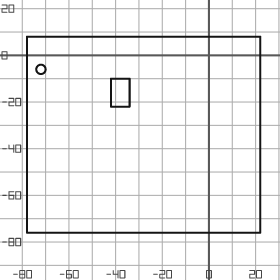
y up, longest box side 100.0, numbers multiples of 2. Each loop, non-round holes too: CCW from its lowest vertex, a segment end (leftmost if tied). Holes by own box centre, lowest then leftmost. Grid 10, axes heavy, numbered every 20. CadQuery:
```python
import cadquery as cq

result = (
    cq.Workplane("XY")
    .moveTo(-78.0, -76.0)
    .lineTo(22.0, -76.0)
    .lineTo(22.0, 8.0)
    .lineTo(-78.0, 8.0)
    .close()
    .moveTo(-42.0, -22.0)
    .lineTo(-34.0, -22.0)
    .lineTo(-34.0, -10.0)
    .lineTo(-42.0, -10.0)
    .close()
    .moveTo(-72.0, -6.0)
    .circle(2.0)
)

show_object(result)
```